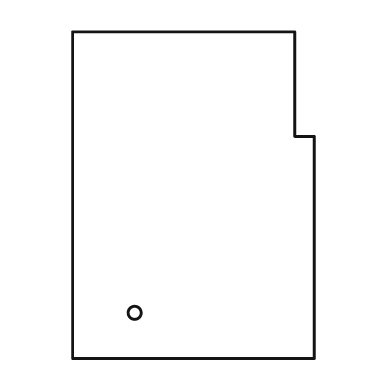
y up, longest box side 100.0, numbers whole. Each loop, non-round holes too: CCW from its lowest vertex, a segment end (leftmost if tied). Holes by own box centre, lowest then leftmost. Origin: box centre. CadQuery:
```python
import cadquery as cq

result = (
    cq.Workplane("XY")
    .moveTo(-37.0, -50.0)
    .lineTo(37.0, -50.0)
    .lineTo(37.0, 18.0)
    .lineTo(31.0, 18.0)
    .lineTo(31.0, 50.0)
    .lineTo(-37.0, 50.0)
    .close()
    .moveTo(-18.0, -36.0)
    .circle(2.0)
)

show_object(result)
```